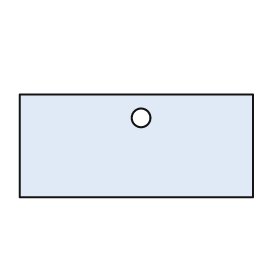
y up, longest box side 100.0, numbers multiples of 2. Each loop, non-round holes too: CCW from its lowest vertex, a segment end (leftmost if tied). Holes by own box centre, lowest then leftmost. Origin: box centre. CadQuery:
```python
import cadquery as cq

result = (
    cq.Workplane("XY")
    .moveTo(-50.0, -22.0)
    .lineTo(50.0, -22.0)
    .lineTo(50.0, 22.0)
    .lineTo(-50.0, 22.0)
    .close()
    .moveTo(2.0, 12.0)
    .circle(4.0)
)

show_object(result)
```